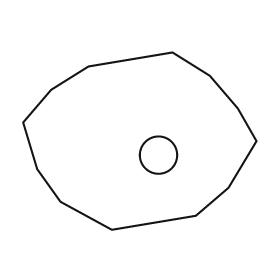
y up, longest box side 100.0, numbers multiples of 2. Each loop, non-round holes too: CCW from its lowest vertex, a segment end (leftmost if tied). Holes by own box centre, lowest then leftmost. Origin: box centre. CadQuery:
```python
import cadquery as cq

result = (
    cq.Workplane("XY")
    .moveTo(-12.0, -38.0)
    .lineTo(24.0, -32.0)
    .lineTo(38.0, -20.0)
    .lineTo(50.0, 0.0)
    .lineTo(42.0, 14.0)
    .lineTo(30.0, 28.0)
    .lineTo(14.0, 38.0)
    .lineTo(-22.0, 32.0)
    .lineTo(-38.0, 22.0)
    .lineTo(-50.0, 8.0)
    .lineTo(-44.0, -12.0)
    .lineTo(-34.0, -26.0)
    .close()
    .moveTo(8.0, -6.0)
    .circle(8.0)
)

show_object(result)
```